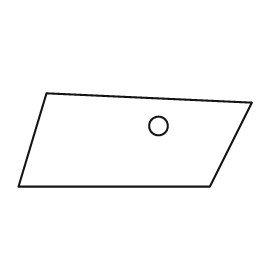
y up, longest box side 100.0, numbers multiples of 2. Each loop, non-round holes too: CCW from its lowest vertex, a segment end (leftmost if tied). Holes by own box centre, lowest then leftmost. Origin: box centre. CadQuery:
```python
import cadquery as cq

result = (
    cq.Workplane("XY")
    .moveTo(-50.0, -20.0)
    .lineTo(32.0, -20.0)
    .lineTo(50.0, 16.0)
    .lineTo(-38.0, 20.0)
    .close()
    .moveTo(10.0, 6.0)
    .circle(4.0)
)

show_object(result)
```